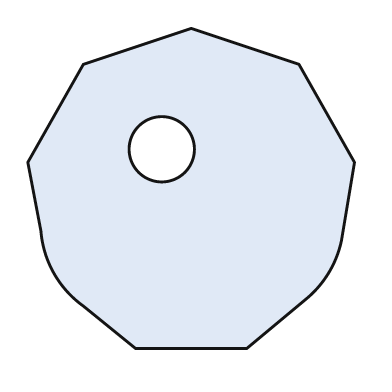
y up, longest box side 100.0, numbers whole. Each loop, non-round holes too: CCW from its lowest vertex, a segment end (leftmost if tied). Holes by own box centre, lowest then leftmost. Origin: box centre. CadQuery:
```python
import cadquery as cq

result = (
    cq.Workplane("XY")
    .moveTo(-17.0, -49.0)
    .lineTo(17.0, -49.0)
    .lineTo(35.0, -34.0)
    .threePointArc((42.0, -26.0), (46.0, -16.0))
    .lineTo(50.0, 8.0)
    .lineTo(33.0, 38.0)
    .lineTo(0.0, 49.0)
    .lineTo(-33.0, 38.0)
    .lineTo(-50.0, 8.0)
    .lineTo(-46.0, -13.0)
    .threePointArc((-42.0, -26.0), (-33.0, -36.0))
    .close()
    .moveTo(-9.0, 12.0)
    .circle(10.0)
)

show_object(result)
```